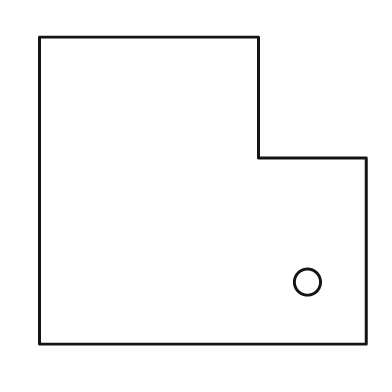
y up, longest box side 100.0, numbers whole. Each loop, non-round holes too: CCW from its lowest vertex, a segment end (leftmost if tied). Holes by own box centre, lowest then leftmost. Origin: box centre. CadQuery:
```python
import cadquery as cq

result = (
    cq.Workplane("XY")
    .moveTo(-50.0, -47.0)
    .lineTo(50.0, -47.0)
    .lineTo(50.0, 10.0)
    .lineTo(17.0, 10.0)
    .lineTo(17.0, 47.0)
    .lineTo(-50.0, 47.0)
    .close()
    .moveTo(32.0, -28.0)
    .circle(4.0)
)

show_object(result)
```